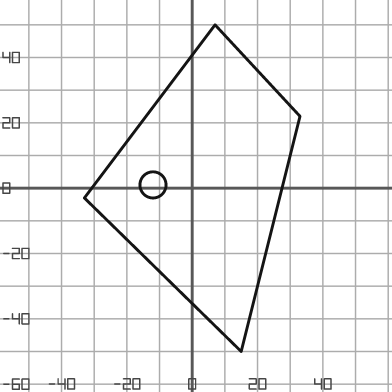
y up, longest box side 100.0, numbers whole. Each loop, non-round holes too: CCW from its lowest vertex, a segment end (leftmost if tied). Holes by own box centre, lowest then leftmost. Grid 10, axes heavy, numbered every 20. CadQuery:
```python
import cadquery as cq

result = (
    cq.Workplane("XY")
    .moveTo(15.0, -50.0)
    .lineTo(33.0, 22.0)
    .lineTo(7.0, 50.0)
    .lineTo(-33.0, -3.0)
    .close()
    .moveTo(-12.0, 1.0)
    .circle(4.0)
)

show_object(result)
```